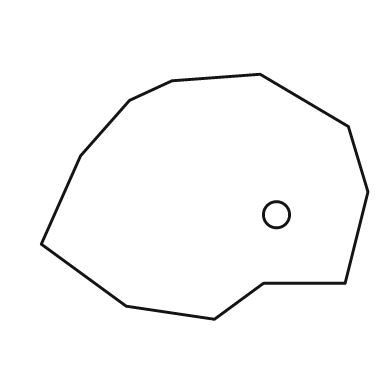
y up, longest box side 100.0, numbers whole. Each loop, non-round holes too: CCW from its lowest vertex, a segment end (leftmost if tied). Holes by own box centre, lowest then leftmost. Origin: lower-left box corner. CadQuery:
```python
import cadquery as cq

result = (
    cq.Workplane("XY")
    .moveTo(53.0, 0.0)
    .lineTo(68.0, 11.0)
    .lineTo(93.0, 11.0)
    .lineTo(100.0, 39.0)
    .lineTo(94.0, 59.0)
    .lineTo(67.0, 75.0)
    .lineTo(40.0, 73.0)
    .lineTo(27.0, 67.0)
    .lineTo(12.0, 50.0)
    .lineTo(0.0, 23.0)
    .lineTo(26.0, 4.0)
    .close()
    .moveTo(72.0, 32.0)
    .circle(4.0)
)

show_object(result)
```